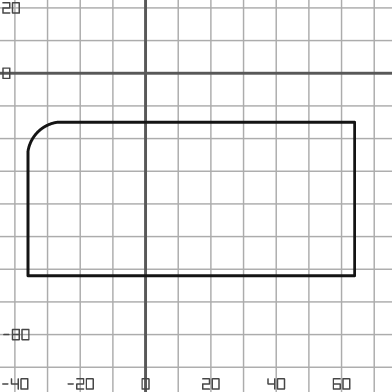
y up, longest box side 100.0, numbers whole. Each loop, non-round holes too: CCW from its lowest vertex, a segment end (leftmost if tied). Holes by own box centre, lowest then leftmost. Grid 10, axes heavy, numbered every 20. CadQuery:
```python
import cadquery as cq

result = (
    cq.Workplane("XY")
    .moveTo(-36.0, -62.0)
    .lineTo(64.0, -62.0)
    .lineTo(64.0, -15.0)
    .lineTo(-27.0, -15.0)
    .threePointArc((-33.0, -18.0), (-36.0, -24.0))
    .close()
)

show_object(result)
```